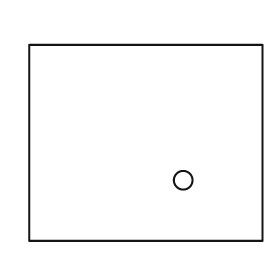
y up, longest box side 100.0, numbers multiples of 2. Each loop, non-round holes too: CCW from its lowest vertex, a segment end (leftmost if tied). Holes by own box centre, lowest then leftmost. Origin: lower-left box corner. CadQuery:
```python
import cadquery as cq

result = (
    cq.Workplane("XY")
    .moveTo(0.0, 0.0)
    .lineTo(100.0, 0.0)
    .lineTo(100.0, 84.0)
    .lineTo(0.0, 84.0)
    .close()
    .moveTo(66.0, 26.0)
    .circle(4.0)
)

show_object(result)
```